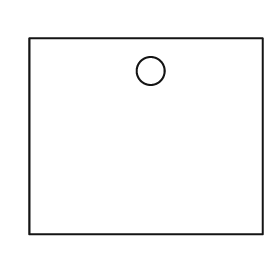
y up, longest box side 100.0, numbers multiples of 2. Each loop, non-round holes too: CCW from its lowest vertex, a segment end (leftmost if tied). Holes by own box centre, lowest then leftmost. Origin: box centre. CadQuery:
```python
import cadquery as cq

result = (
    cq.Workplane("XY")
    .moveTo(-50.0, -42.0)
    .lineTo(50.0, -42.0)
    .lineTo(50.0, 42.0)
    .lineTo(-50.0, 42.0)
    .close()
    .moveTo(2.0, 28.0)
    .circle(6.0)
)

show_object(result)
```